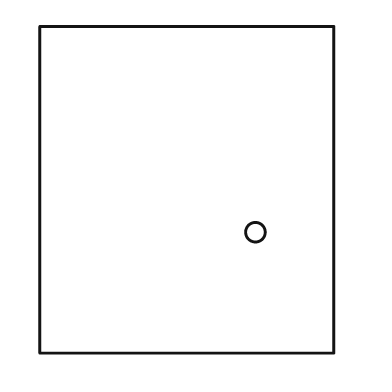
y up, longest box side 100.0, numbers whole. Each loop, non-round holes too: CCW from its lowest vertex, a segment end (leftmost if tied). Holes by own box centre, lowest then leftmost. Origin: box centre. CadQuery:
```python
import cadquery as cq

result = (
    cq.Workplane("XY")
    .moveTo(-45.0, -50.0)
    .lineTo(45.0, -50.0)
    .lineTo(45.0, 50.0)
    .lineTo(-45.0, 50.0)
    .close()
    .moveTo(21.0, -13.0)
    .circle(3.0)
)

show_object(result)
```